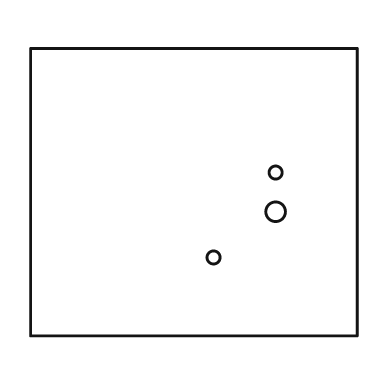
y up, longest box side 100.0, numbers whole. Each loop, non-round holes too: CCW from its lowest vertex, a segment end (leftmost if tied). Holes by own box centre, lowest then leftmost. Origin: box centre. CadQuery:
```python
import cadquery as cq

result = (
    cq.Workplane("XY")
    .moveTo(-50.0, -44.0)
    .lineTo(50.0, -44.0)
    .lineTo(50.0, 44.0)
    .lineTo(-50.0, 44.0)
    .close()
    .moveTo(6.0, -20.0)
    .circle(2.0)
    .moveTo(25.0, -6.0)
    .circle(3.0)
    .moveTo(25.0, 6.0)
    .circle(2.0)
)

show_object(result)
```